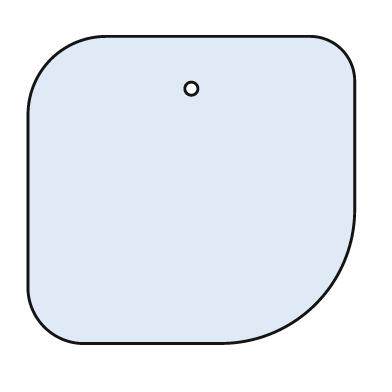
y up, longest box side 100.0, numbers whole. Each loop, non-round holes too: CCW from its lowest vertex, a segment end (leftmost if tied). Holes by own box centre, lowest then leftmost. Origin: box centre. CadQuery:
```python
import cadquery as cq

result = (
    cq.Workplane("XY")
    .moveTo(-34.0, -47.0)
    .lineTo(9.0, -47.0)
    .threePointArc((38.0, -35.0), (50.0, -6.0))
    .lineTo(50.0, 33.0)
    .threePointArc((46.0, 43.0), (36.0, 47.0))
    .lineTo(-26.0, 47.0)
    .threePointArc((-43.0, 40.0), (-50.0, 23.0))
    .lineTo(-50.0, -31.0)
    .threePointArc((-45.0, -42.0), (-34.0, -47.0))
    .close()
    .moveTo(0.0, 31.0)
    .circle(2.0)
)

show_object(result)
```